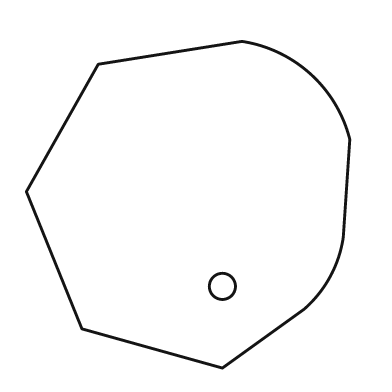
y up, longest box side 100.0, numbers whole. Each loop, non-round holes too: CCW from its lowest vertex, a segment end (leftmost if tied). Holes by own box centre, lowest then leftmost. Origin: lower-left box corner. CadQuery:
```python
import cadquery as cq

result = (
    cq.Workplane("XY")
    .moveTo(60.0, 0.0)
    .lineTo(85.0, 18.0)
    .threePointArc((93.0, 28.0), (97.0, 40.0))
    .lineTo(99.0, 70.0)
    .threePointArc((87.0, 90.0), (66.0, 100.0))
    .lineTo(22.0, 93.0)
    .lineTo(0.0, 54.0)
    .lineTo(17.0, 12.0)
    .close()
    .moveTo(60.0, 25.0)
    .circle(4.0)
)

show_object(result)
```